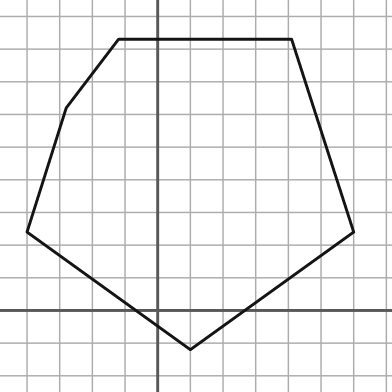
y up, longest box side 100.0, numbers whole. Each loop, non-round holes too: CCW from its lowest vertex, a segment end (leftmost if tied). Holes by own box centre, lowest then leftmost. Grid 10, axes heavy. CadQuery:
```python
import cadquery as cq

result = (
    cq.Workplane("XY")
    .moveTo(10.0, -12.0)
    .lineTo(60.0, 24.0)
    .lineTo(41.0, 83.0)
    .lineTo(-12.0, 83.0)
    .lineTo(-28.0, 62.0)
    .lineTo(-40.0, 24.0)
    .close()
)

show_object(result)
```